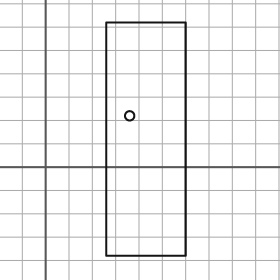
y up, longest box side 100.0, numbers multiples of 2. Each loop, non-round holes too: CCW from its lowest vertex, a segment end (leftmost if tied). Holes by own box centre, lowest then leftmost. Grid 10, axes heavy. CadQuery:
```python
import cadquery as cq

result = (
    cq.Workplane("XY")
    .moveTo(26.0, -38.0)
    .lineTo(60.0, -38.0)
    .lineTo(60.0, 62.0)
    .lineTo(26.0, 62.0)
    .close()
    .moveTo(36.0, 22.0)
    .circle(2.0)
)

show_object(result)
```